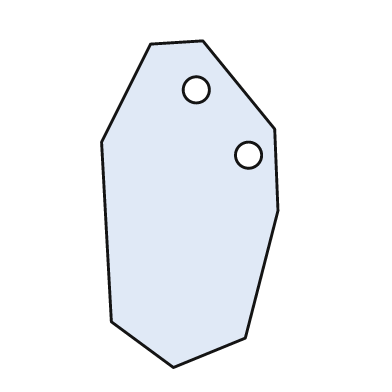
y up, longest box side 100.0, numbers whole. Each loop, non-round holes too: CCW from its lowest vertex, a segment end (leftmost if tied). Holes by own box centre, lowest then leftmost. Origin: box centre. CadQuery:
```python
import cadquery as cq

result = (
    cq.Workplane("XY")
    .moveTo(-5.0, -50.0)
    .lineTo(17.0, -41.0)
    .lineTo(27.0, -2.0)
    .lineTo(26.0, 23.0)
    .lineTo(4.0, 50.0)
    .lineTo(-12.0, 49.0)
    .lineTo(-27.0, 19.0)
    .lineTo(-24.0, -36.0)
    .close()
    .moveTo(18.0, 15.0)
    .circle(4.0)
    .moveTo(2.0, 35.0)
    .circle(4.0)
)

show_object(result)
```